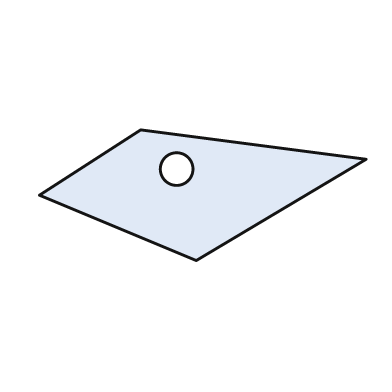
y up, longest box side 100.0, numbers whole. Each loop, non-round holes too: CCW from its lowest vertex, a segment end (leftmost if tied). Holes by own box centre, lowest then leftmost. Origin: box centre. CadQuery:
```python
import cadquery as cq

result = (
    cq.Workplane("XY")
    .moveTo(-2.0, -20.0)
    .lineTo(50.0, 11.0)
    .lineTo(-19.0, 20.0)
    .lineTo(-50.0, 0.0)
    .close()
    .moveTo(-8.0, 8.0)
    .circle(5.0)
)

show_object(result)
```